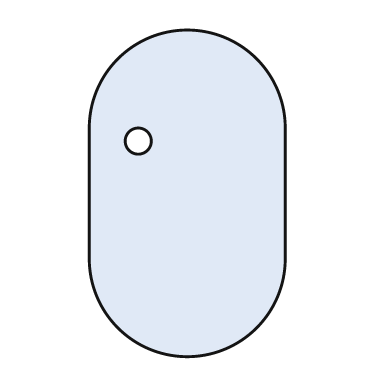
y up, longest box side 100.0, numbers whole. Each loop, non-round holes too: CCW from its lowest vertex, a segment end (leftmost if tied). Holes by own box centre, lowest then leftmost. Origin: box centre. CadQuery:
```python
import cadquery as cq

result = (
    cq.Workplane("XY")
    .moveTo(-30.0, -20.0)
    .threePointArc((0.0, -50.0), (30.0, -20.0))
    .lineTo(30.0, 20.0)
    .threePointArc((0.0, 50.0), (-30.0, 20.0))
    .close()
    .moveTo(-15.0, 16.0)
    .circle(4.0)
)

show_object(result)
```